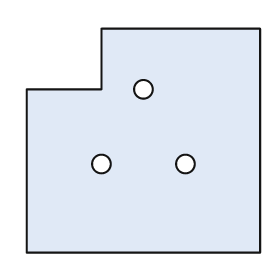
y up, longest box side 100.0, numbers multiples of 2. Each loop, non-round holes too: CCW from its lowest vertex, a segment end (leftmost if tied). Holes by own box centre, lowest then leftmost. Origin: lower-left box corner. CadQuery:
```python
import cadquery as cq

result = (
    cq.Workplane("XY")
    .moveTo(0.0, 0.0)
    .lineTo(100.0, 0.0)
    .lineTo(100.0, 96.0)
    .lineTo(32.0, 96.0)
    .lineTo(32.0, 70.0)
    .lineTo(0.0, 70.0)
    .close()
    .moveTo(32.0, 38.0)
    .circle(4.0)
    .moveTo(68.0, 38.0)
    .circle(4.0)
    .moveTo(50.0, 70.0)
    .circle(4.0)
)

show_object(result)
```